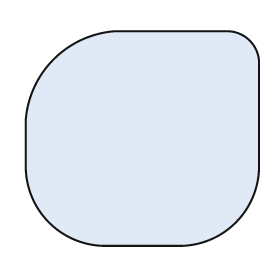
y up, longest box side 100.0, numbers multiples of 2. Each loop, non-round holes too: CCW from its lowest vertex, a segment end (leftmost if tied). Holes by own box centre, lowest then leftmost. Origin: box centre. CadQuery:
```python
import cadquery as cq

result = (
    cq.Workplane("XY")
    .moveTo(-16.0, -46.0)
    .lineTo(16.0, -46.0)
    .threePointArc((40.0, -36.0), (50.0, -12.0))
    .lineTo(50.0, 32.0)
    .threePointArc((46.0, 42.0), (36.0, 46.0))
    .lineTo(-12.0, 46.0)
    .threePointArc((-38.0, 34.0), (-50.0, 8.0))
    .lineTo(-50.0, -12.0)
    .threePointArc((-40.0, -36.0), (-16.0, -46.0))
    .close()
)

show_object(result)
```